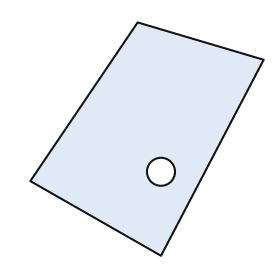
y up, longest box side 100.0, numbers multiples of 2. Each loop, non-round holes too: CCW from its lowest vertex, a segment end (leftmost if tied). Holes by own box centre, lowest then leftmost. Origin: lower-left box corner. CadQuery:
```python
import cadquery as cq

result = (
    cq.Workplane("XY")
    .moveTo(56.0, 0.0)
    .lineTo(100.0, 84.0)
    .lineTo(46.0, 100.0)
    .lineTo(0.0, 32.0)
    .close()
    .moveTo(56.0, 36.0)
    .circle(6.0)
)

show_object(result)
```